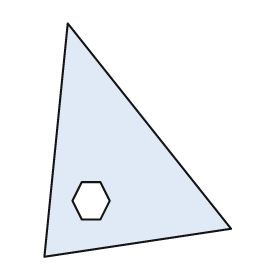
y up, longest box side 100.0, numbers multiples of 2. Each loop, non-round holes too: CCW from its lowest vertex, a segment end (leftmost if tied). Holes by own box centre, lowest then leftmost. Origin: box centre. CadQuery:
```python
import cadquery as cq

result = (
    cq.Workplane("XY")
    .moveTo(-40.0, -50.0)
    .lineTo(40.0, -38.0)
    .lineTo(-30.0, 50.0)
    .close()
    .moveTo(-24.0, -34.0)
    .lineTo(-16.0, -34.0)
    .lineTo(-12.0, -26.0)
    .lineTo(-16.0, -18.0)
    .lineTo(-24.0, -18.0)
    .lineTo(-28.0, -26.0)
    .close()
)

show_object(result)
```